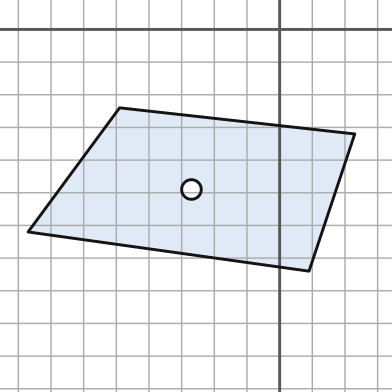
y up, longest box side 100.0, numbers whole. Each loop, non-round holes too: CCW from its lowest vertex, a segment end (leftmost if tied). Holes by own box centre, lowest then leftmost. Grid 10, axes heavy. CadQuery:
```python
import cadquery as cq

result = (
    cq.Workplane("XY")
    .moveTo(9.0, -74.0)
    .lineTo(23.0, -32.0)
    .lineTo(-49.0, -24.0)
    .lineTo(-77.0, -62.0)
    .close()
    .moveTo(-27.0, -49.0)
    .circle(3.0)
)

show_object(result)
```